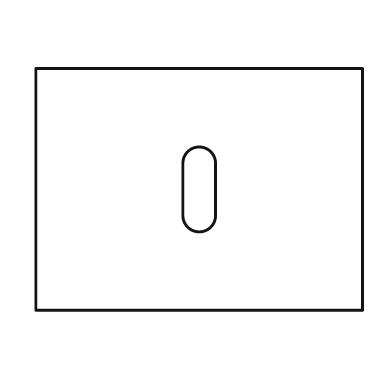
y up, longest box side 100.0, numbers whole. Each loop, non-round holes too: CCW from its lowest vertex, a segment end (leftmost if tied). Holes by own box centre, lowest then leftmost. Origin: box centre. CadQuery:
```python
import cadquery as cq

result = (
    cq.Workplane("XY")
    .moveTo(-50.0, -37.0)
    .lineTo(50.0, -37.0)
    .lineTo(50.0, 37.0)
    .lineTo(-50.0, 37.0)
    .close()
    .moveTo(-5.0, -8.0)
    .threePointArc((0.0, -13.0), (5.0, -8.0))
    .lineTo(5.0, 8.0)
    .threePointArc((0.0, 13.0), (-5.0, 8.0))
    .close()
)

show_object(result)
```